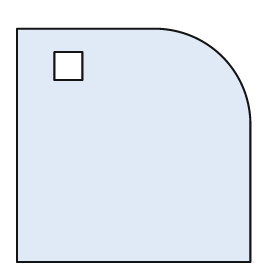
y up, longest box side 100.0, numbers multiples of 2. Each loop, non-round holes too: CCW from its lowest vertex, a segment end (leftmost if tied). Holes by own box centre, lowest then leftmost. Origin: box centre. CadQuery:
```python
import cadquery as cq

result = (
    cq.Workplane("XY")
    .moveTo(-50.0, -50.0)
    .lineTo(50.0, -50.0)
    .lineTo(50.0, 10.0)
    .threePointArc((38.0, 38.0), (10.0, 50.0))
    .lineTo(-50.0, 50.0)
    .close()
    .moveTo(-34.0, 28.0)
    .lineTo(-22.0, 28.0)
    .lineTo(-22.0, 40.0)
    .lineTo(-34.0, 40.0)
    .close()
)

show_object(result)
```